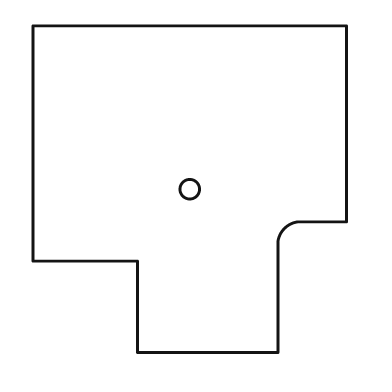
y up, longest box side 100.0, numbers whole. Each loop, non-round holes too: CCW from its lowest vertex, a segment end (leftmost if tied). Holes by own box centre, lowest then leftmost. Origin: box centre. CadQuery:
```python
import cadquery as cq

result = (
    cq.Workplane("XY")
    .moveTo(-16.0, -50.0)
    .lineTo(27.0, -50.0)
    .lineTo(27.0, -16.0)
    .threePointArc((29.0, -12.0), (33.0, -10.0))
    .lineTo(48.0, -10.0)
    .lineTo(48.0, 50.0)
    .lineTo(-48.0, 50.0)
    .lineTo(-48.0, -22.0)
    .lineTo(-16.0, -22.0)
    .close()
    .moveTo(0.0, 0.0)
    .circle(3.0)
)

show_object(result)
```